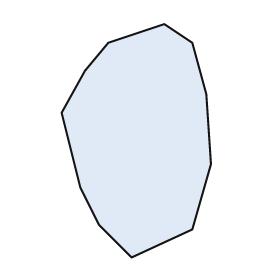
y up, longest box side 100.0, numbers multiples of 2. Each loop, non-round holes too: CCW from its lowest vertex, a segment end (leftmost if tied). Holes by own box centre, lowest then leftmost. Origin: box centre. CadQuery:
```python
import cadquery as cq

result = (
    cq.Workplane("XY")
    .moveTo(-2.0, -50.0)
    .lineTo(24.0, -38.0)
    .lineTo(32.0, -10.0)
    .lineTo(30.0, 20.0)
    .lineTo(24.0, 42.0)
    .lineTo(12.0, 50.0)
    .lineTo(-12.0, 42.0)
    .lineTo(-22.0, 30.0)
    .lineTo(-32.0, 12.0)
    .lineTo(-24.0, -20.0)
    .lineTo(-16.0, -36.0)
    .close()
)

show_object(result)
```